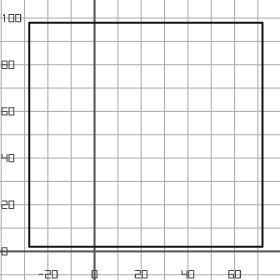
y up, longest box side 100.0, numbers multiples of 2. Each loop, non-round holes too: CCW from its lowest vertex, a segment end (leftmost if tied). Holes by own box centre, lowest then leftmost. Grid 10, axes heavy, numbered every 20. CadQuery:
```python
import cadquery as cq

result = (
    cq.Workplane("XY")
    .moveTo(-28.0, 2.0)
    .lineTo(72.0, 2.0)
    .lineTo(72.0, 98.0)
    .lineTo(-28.0, 98.0)
    .close()
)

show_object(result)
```